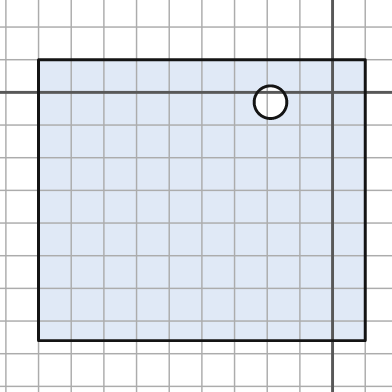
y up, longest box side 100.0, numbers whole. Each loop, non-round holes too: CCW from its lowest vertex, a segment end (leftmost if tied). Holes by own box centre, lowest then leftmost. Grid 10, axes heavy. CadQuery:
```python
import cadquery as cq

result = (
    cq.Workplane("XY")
    .moveTo(-90.0, -76.0)
    .lineTo(10.0, -76.0)
    .lineTo(10.0, 10.0)
    .lineTo(-90.0, 10.0)
    .close()
    .moveTo(-19.0, -3.0)
    .circle(5.0)
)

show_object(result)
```